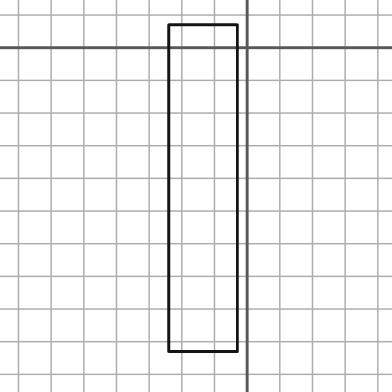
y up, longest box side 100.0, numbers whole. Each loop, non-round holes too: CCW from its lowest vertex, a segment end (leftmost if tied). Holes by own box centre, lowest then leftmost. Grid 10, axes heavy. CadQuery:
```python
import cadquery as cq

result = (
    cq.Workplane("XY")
    .moveTo(-24.0, -93.0)
    .lineTo(-3.0, -93.0)
    .lineTo(-3.0, 7.0)
    .lineTo(-24.0, 7.0)
    .close()
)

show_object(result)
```